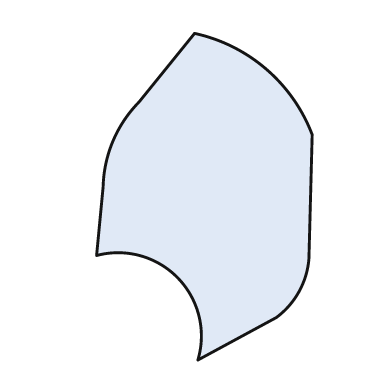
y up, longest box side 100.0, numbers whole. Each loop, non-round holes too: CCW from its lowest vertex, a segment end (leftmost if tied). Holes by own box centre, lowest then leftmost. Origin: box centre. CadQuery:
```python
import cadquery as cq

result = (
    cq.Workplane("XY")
    .moveTo(-2.0, -50.0)
    .lineTo(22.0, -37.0)
    .threePointArc((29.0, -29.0), (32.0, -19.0))
    .lineTo(33.0, 19.0)
    .threePointArc((19.0, 39.0), (-3.0, 50.0))
    .lineTo(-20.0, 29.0)
    .threePointArc((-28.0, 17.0), (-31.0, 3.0))
    .lineTo(-33.0, -18.0)
    .threePointArc((-8.0, -25.0), (-2.0, -50.0))
    .close()
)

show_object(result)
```